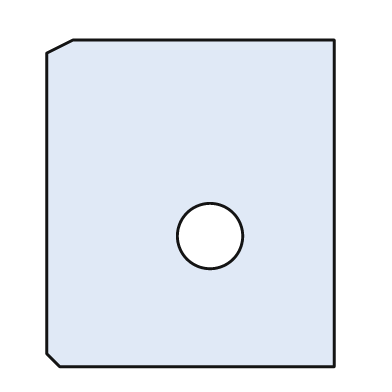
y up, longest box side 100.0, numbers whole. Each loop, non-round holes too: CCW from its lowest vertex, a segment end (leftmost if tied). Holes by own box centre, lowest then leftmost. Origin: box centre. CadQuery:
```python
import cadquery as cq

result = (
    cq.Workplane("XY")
    .moveTo(-40.0, -50.0)
    .lineTo(44.0, -50.0)
    .lineTo(44.0, 50.0)
    .lineTo(-36.0, 50.0)
    .lineTo(-44.0, 46.0)
    .lineTo(-44.0, -46.0)
    .close()
    .moveTo(6.0, -10.0)
    .circle(10.0)
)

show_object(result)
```